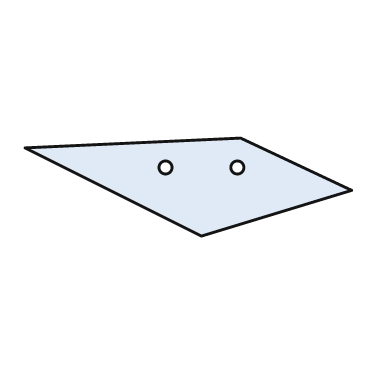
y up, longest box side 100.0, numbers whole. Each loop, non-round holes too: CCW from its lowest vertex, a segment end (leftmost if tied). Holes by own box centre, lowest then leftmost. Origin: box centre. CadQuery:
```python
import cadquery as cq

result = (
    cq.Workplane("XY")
    .moveTo(4.0, -15.0)
    .lineTo(50.0, -1.0)
    .lineTo(16.0, 15.0)
    .lineTo(-50.0, 12.0)
    .close()
    .moveTo(-7.0, 6.0)
    .circle(2.0)
    .moveTo(15.0, 6.0)
    .circle(2.0)
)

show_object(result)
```